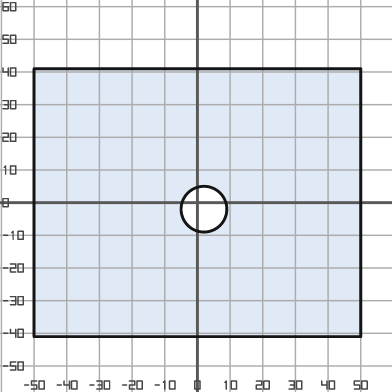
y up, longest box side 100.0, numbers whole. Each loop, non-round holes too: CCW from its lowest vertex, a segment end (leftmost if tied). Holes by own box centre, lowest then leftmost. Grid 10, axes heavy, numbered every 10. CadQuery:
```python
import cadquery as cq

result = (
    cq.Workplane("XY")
    .moveTo(-50.0, -41.0)
    .lineTo(50.0, -41.0)
    .lineTo(50.0, 41.0)
    .lineTo(-50.0, 41.0)
    .close()
    .moveTo(2.0, -2.0)
    .circle(7.0)
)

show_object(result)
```